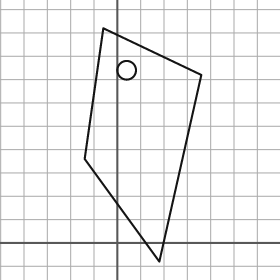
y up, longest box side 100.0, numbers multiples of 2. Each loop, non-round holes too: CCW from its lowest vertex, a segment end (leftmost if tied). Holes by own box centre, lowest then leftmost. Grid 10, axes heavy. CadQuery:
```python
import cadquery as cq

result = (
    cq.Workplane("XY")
    .moveTo(18.0, -8.0)
    .lineTo(36.0, 72.0)
    .lineTo(-6.0, 92.0)
    .lineTo(-14.0, 36.0)
    .close()
    .moveTo(4.0, 74.0)
    .circle(4.0)
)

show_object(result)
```